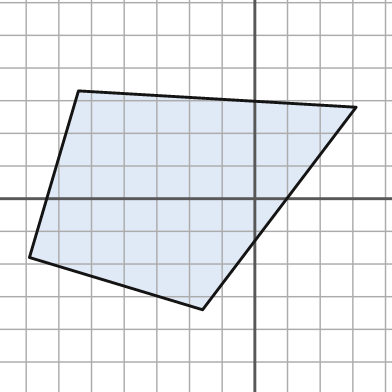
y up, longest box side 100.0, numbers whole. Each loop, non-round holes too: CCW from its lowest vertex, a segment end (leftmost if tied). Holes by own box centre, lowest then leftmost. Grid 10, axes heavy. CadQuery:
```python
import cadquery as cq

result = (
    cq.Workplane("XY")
    .moveTo(-16.0, -34.0)
    .lineTo(31.0, 28.0)
    .lineTo(-54.0, 33.0)
    .lineTo(-69.0, -18.0)
    .close()
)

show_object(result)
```